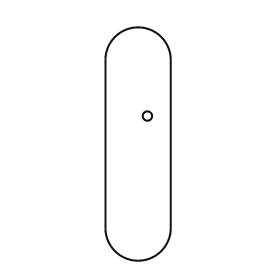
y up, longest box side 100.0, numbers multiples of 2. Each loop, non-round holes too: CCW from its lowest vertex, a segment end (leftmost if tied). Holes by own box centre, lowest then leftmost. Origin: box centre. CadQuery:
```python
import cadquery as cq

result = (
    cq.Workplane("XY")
    .moveTo(-14.0, -36.0)
    .threePointArc((0.0, -50.0), (14.0, -36.0))
    .lineTo(14.0, 36.0)
    .threePointArc((0.0, 50.0), (-14.0, 36.0))
    .close()
    .moveTo(4.0, 12.0)
    .circle(2.0)
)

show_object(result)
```